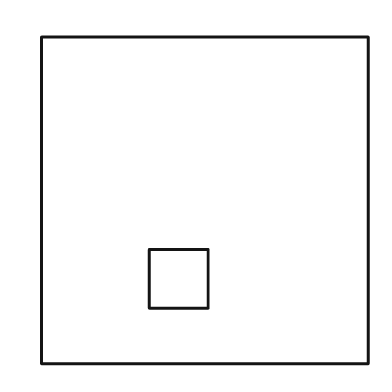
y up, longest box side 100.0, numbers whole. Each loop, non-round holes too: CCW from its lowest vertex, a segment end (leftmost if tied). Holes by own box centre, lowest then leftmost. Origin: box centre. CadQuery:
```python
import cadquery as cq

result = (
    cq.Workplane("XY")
    .moveTo(-50.0, -50.0)
    .lineTo(50.0, -50.0)
    .lineTo(50.0, 50.0)
    .lineTo(-50.0, 50.0)
    .close()
    .moveTo(-17.0, -33.0)
    .lineTo(1.0, -33.0)
    .lineTo(1.0, -15.0)
    .lineTo(-17.0, -15.0)
    .close()
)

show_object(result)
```